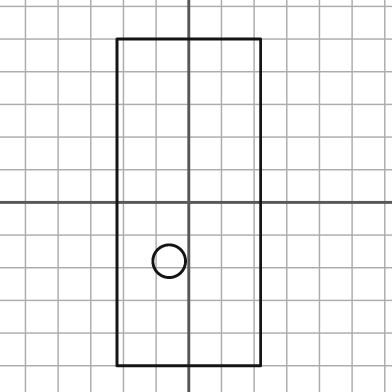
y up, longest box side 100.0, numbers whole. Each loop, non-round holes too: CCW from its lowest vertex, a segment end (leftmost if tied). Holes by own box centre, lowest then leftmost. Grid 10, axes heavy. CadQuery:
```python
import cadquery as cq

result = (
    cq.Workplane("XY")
    .moveTo(-22.0, -50.0)
    .lineTo(22.0, -50.0)
    .lineTo(22.0, 50.0)
    .lineTo(-22.0, 50.0)
    .close()
    .moveTo(-6.0, -18.0)
    .circle(5.0)
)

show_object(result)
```